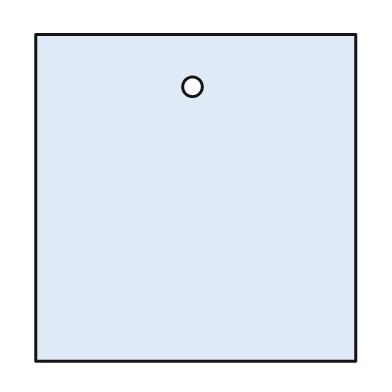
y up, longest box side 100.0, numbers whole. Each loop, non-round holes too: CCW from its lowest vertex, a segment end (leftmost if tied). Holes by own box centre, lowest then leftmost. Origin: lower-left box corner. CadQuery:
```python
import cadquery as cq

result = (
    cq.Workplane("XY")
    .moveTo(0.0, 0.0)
    .lineTo(98.0, 0.0)
    .lineTo(98.0, 100.0)
    .lineTo(0.0, 100.0)
    .close()
    .moveTo(48.0, 84.0)
    .circle(3.0)
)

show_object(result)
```